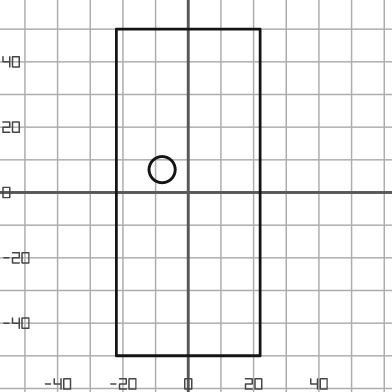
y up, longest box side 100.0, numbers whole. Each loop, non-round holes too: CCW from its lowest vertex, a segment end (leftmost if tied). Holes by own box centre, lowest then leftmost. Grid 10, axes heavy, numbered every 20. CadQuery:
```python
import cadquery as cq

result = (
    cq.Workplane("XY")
    .moveTo(-22.0, -50.0)
    .lineTo(22.0, -50.0)
    .lineTo(22.0, 50.0)
    .lineTo(-22.0, 50.0)
    .close()
    .moveTo(-8.0, 7.0)
    .circle(4.0)
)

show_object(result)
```